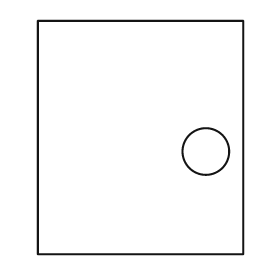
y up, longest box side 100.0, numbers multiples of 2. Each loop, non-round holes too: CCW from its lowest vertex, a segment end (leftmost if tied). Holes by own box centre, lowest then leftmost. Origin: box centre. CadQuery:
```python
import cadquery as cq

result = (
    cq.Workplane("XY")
    .moveTo(-44.0, -50.0)
    .lineTo(44.0, -50.0)
    .lineTo(44.0, 50.0)
    .lineTo(-44.0, 50.0)
    .close()
    .moveTo(28.0, -6.0)
    .circle(10.0)
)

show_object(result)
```